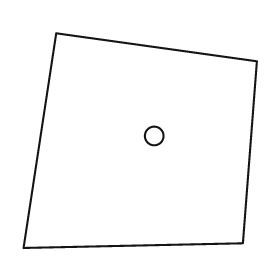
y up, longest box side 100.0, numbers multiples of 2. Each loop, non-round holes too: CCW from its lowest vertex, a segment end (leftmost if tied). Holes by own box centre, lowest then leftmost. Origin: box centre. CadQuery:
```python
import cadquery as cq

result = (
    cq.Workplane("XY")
    .moveTo(-50.0, -46.0)
    .lineTo(44.0, -44.0)
    .lineTo(50.0, 34.0)
    .lineTo(-36.0, 46.0)
    .close()
    .moveTo(6.0, 2.0)
    .circle(4.0)
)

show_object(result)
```